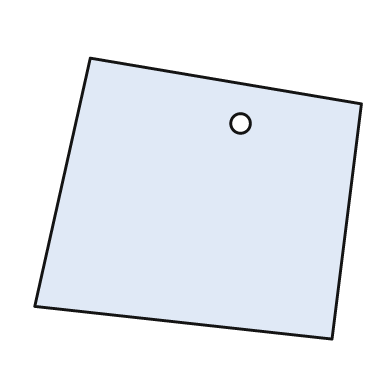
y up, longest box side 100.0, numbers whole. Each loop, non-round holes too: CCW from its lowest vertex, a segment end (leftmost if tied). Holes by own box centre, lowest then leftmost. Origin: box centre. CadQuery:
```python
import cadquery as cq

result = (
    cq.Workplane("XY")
    .moveTo(41.0, -43.0)
    .lineTo(50.0, 29.0)
    .lineTo(-33.0, 43.0)
    .lineTo(-50.0, -33.0)
    .close()
    .moveTo(13.0, 23.0)
    .circle(3.0)
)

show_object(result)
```